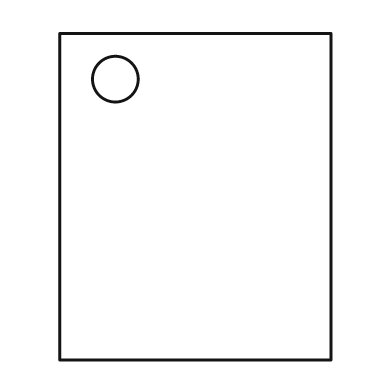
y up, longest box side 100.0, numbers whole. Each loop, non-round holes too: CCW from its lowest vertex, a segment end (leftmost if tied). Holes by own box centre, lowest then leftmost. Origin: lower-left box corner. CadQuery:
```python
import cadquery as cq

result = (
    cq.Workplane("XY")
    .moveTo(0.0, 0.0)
    .lineTo(83.0, 0.0)
    .lineTo(83.0, 100.0)
    .lineTo(0.0, 100.0)
    .close()
    .moveTo(17.0, 86.0)
    .circle(7.0)
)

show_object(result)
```